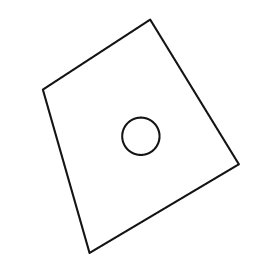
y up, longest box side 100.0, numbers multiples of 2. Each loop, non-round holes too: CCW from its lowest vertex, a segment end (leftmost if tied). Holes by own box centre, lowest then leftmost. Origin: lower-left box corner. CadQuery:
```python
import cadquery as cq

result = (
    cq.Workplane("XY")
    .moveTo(20.0, 0.0)
    .lineTo(84.0, 38.0)
    .lineTo(46.0, 100.0)
    .lineTo(0.0, 70.0)
    .close()
    .moveTo(42.0, 50.0)
    .circle(8.0)
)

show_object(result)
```